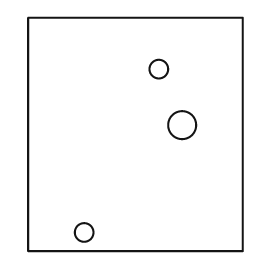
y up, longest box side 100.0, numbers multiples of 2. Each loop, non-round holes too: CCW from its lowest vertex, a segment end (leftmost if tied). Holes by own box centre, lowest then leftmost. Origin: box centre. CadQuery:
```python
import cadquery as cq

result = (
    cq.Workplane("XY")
    .moveTo(-46.0, -50.0)
    .lineTo(46.0, -50.0)
    .lineTo(46.0, 50.0)
    .lineTo(-46.0, 50.0)
    .close()
    .moveTo(-22.0, -42.0)
    .circle(4.0)
    .moveTo(20.0, 4.0)
    .circle(6.0)
    .moveTo(10.0, 28.0)
    .circle(4.0)
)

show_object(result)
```